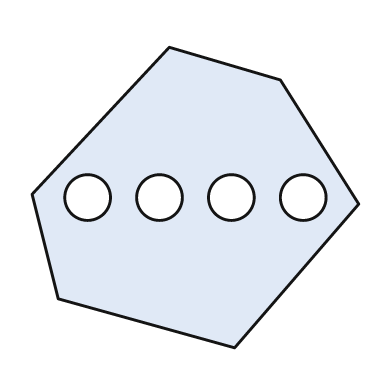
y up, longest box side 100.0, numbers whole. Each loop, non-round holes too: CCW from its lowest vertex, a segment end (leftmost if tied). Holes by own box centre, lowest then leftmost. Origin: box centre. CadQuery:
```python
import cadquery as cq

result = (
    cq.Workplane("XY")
    .moveTo(12.0, -46.0)
    .lineTo(50.0, -2.0)
    .lineTo(26.0, 36.0)
    .lineTo(-8.0, 46.0)
    .lineTo(-50.0, 1.0)
    .lineTo(-42.0, -31.0)
    .close()
    .moveTo(-33.0, 0.0)
    .circle(7.0)
    .moveTo(-11.0, 0.0)
    .circle(7.0)
    .moveTo(11.0, 0.0)
    .circle(7.0)
    .moveTo(33.0, 0.0)
    .circle(7.0)
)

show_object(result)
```